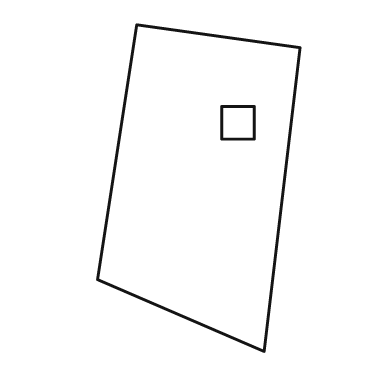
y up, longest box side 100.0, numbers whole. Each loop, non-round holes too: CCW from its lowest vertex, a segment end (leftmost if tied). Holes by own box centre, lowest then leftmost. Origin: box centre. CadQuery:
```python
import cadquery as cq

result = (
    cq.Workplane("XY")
    .moveTo(20.0, -50.0)
    .lineTo(31.0, 43.0)
    .lineTo(-19.0, 50.0)
    .lineTo(-31.0, -28.0)
    .close()
    .moveTo(7.0, 15.0)
    .lineTo(17.0, 15.0)
    .lineTo(17.0, 25.0)
    .lineTo(7.0, 25.0)
    .close()
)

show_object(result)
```